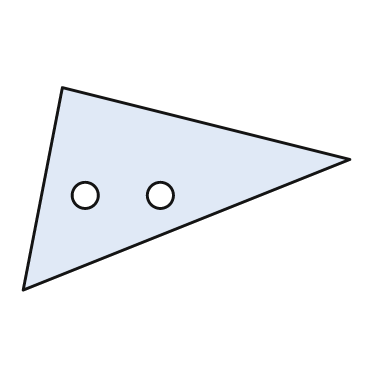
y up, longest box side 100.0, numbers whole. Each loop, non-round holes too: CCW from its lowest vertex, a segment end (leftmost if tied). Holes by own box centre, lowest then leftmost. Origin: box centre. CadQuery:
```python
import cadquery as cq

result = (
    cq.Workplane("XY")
    .moveTo(-50.0, -31.0)
    .lineTo(50.0, 9.0)
    .lineTo(-38.0, 31.0)
    .close()
    .moveTo(-31.0, -2.0)
    .circle(4.0)
    .moveTo(-8.0, -2.0)
    .circle(4.0)
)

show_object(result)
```